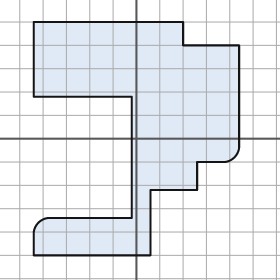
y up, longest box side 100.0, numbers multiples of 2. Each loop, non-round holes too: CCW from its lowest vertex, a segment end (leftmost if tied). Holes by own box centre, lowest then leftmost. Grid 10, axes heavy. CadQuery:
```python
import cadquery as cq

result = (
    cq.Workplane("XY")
    .moveTo(-44.0, -50.0)
    .lineTo(6.0, -50.0)
    .lineTo(6.0, -22.0)
    .lineTo(26.0, -22.0)
    .lineTo(26.0, -10.0)
    .lineTo(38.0, -10.0)
    .threePointArc((42.0, -8.0), (44.0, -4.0))
    .lineTo(44.0, 40.0)
    .lineTo(20.0, 40.0)
    .lineTo(20.0, 50.0)
    .lineTo(-44.0, 50.0)
    .lineTo(-44.0, 18.0)
    .lineTo(-2.0, 18.0)
    .lineTo(-2.0, -34.0)
    .lineTo(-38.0, -34.0)
    .threePointArc((-42.0, -36.0), (-44.0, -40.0))
    .close()
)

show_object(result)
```